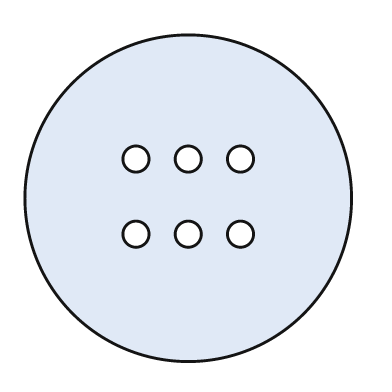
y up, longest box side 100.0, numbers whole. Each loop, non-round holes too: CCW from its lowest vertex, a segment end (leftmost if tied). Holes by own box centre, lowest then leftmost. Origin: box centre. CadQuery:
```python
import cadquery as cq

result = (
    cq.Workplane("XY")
    .moveTo(0.0, 0.0)
    .circle(50.0)
    .moveTo(-16.0, -11.0)
    .circle(4.0)
    .moveTo(0.0, -11.0)
    .circle(4.0)
    .moveTo(16.0, -11.0)
    .circle(4.0)
    .moveTo(-16.0, 12.0)
    .circle(4.0)
    .moveTo(0.0, 12.0)
    .circle(4.0)
    .moveTo(16.0, 12.0)
    .circle(4.0)
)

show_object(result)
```